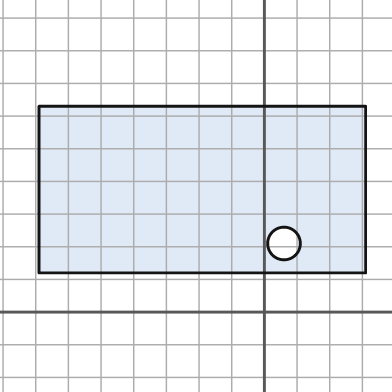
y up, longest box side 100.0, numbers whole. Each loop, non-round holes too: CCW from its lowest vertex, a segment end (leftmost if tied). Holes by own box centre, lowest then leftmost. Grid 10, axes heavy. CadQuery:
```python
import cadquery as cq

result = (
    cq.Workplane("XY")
    .moveTo(-69.0, 12.0)
    .lineTo(31.0, 12.0)
    .lineTo(31.0, 63.0)
    .lineTo(-69.0, 63.0)
    .close()
    .moveTo(6.0, 21.0)
    .circle(5.0)
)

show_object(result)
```